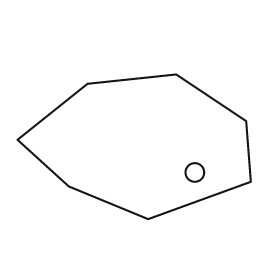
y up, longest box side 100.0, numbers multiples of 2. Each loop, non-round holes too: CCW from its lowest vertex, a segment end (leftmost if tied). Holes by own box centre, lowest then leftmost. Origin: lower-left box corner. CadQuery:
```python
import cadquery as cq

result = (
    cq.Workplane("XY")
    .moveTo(56.0, 0.0)
    .lineTo(100.0, 16.0)
    .lineTo(98.0, 42.0)
    .lineTo(68.0, 62.0)
    .lineTo(30.0, 58.0)
    .lineTo(0.0, 34.0)
    .lineTo(22.0, 14.0)
    .close()
    .moveTo(76.0, 20.0)
    .circle(4.0)
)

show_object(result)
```